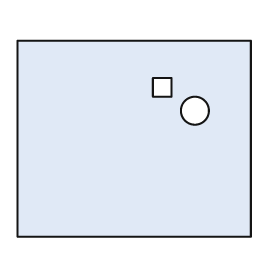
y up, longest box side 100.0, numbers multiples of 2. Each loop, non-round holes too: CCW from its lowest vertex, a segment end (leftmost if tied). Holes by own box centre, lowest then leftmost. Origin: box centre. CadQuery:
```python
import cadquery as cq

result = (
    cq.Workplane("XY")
    .moveTo(-50.0, -42.0)
    .lineTo(50.0, -42.0)
    .lineTo(50.0, 42.0)
    .lineTo(-50.0, 42.0)
    .close()
    .moveTo(26.0, 12.0)
    .circle(6.0)
    .moveTo(8.0, 18.0)
    .lineTo(16.0, 18.0)
    .lineTo(16.0, 26.0)
    .lineTo(8.0, 26.0)
    .close()
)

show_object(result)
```